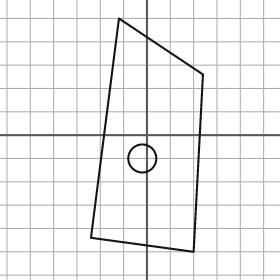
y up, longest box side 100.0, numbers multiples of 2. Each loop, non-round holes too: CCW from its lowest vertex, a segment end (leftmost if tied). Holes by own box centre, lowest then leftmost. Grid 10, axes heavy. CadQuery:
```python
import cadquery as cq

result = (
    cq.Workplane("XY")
    .moveTo(20.0, -50.0)
    .lineTo(24.0, 26.0)
    .lineTo(-12.0, 50.0)
    .lineTo(-24.0, -44.0)
    .close()
    .moveTo(-2.0, -10.0)
    .circle(6.0)
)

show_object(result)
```